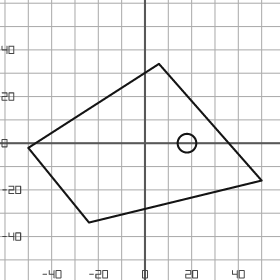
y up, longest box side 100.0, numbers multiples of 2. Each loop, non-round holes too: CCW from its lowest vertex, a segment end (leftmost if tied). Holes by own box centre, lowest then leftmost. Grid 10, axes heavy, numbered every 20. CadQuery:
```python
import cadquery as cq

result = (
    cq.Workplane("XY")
    .moveTo(-24.0, -34.0)
    .lineTo(50.0, -16.0)
    .lineTo(6.0, 34.0)
    .lineTo(-50.0, -2.0)
    .close()
    .moveTo(18.0, 0.0)
    .circle(4.0)
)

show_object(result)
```